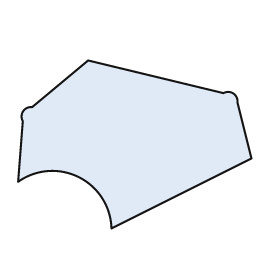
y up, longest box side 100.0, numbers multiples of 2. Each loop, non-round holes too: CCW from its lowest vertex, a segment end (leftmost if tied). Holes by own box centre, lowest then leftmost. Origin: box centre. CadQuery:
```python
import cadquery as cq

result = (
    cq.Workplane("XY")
    .moveTo(-10.0, -36.0)
    .lineTo(50.0, -6.0)
    .lineTo(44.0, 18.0)
    .threePointArc((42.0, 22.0), (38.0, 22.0))
    .lineTo(-20.0, 36.0)
    .lineTo(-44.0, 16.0)
    .threePointArc((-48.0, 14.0), (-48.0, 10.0))
    .lineTo(-50.0, -16.0)
    .threePointArc((-24.0, -14.0), (-10.0, -36.0))
    .close()
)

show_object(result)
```